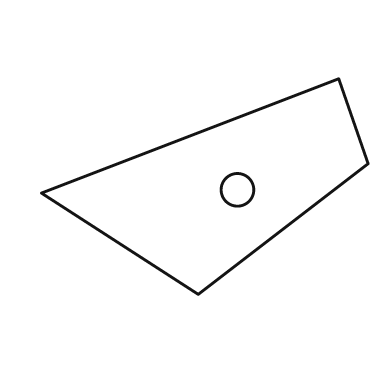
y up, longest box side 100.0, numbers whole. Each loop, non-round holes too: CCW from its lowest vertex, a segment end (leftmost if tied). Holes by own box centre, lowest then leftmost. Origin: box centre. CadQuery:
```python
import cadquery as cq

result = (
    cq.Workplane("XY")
    .moveTo(-2.0, -33.0)
    .lineTo(50.0, 7.0)
    .lineTo(41.0, 33.0)
    .lineTo(-50.0, -2.0)
    .close()
    .moveTo(10.0, -1.0)
    .circle(5.0)
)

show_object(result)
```